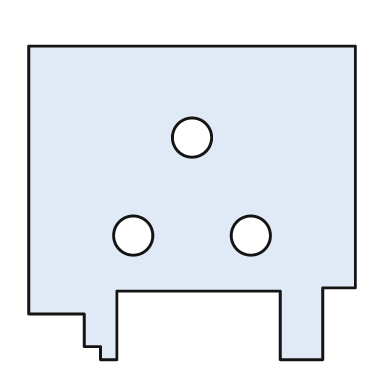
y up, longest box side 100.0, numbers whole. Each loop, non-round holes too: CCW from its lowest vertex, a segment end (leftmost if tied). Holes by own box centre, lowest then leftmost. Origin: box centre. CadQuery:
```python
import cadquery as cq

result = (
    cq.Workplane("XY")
    .moveTo(-28.0, -48.0)
    .lineTo(-23.0, -48.0)
    .lineTo(-23.0, -27.0)
    .lineTo(27.0, -27.0)
    .lineTo(27.0, -48.0)
    .lineTo(40.0, -48.0)
    .lineTo(40.0, -26.0)
    .lineTo(50.0, -26.0)
    .lineTo(50.0, 48.0)
    .lineTo(-50.0, 48.0)
    .lineTo(-50.0, -34.0)
    .lineTo(-33.0, -34.0)
    .lineTo(-33.0, -44.0)
    .lineTo(-28.0, -44.0)
    .close()
    .moveTo(-18.0, -10.0)
    .circle(6.0)
    .moveTo(18.0, -10.0)
    .circle(6.0)
    .moveTo(0.0, 20.0)
    .circle(6.0)
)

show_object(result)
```